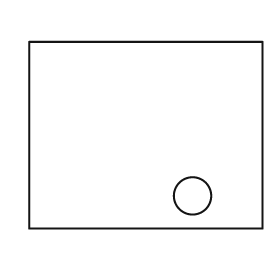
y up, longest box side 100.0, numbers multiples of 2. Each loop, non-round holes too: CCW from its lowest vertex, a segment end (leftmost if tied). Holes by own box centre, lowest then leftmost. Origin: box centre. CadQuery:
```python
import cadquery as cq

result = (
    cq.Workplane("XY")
    .moveTo(-50.0, -40.0)
    .lineTo(50.0, -40.0)
    .lineTo(50.0, 40.0)
    .lineTo(-50.0, 40.0)
    .close()
    .moveTo(20.0, -26.0)
    .circle(8.0)
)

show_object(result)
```